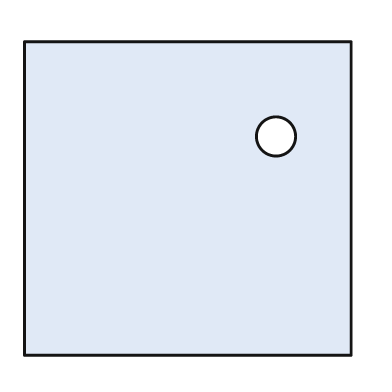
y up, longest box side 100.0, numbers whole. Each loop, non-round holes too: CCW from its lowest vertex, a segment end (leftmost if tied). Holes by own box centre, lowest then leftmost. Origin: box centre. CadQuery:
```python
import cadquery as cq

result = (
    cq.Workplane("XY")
    .moveTo(-50.0, -48.0)
    .lineTo(50.0, -48.0)
    .lineTo(50.0, 48.0)
    .lineTo(-50.0, 48.0)
    .close()
    .moveTo(27.0, 19.0)
    .circle(6.0)
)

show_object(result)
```